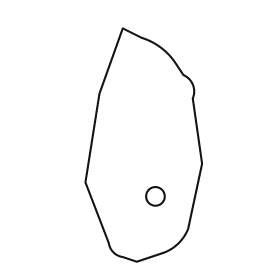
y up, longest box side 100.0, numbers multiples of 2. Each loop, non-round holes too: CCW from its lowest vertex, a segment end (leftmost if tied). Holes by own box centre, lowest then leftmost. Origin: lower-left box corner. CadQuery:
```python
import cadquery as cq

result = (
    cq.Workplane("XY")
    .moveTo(22.0, 0.0)
    .lineTo(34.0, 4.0)
    .threePointArc((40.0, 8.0), (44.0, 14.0))
    .lineTo(50.0, 42.0)
    .lineTo(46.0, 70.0)
    .threePointArc((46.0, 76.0), (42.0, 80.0))
    .lineTo(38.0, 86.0)
    .threePointArc((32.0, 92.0), (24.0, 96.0))
    .lineTo(16.0, 100.0)
    .lineTo(6.0, 72.0)
    .lineTo(0.0, 34.0)
    .lineTo(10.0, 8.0)
    .threePointArc((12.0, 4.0), (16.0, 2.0))
    .close()
    .moveTo(30.0, 28.0)
    .circle(4.0)
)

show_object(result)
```